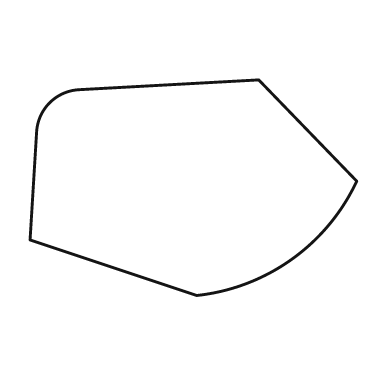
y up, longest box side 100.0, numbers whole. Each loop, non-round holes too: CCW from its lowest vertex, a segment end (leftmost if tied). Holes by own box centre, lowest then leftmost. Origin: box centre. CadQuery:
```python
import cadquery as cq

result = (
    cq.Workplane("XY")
    .moveTo(1.0, -33.0)
    .threePointArc((30.0, -22.0), (50.0, 2.0))
    .lineTo(20.0, 33.0)
    .lineTo(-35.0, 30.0)
    .threePointArc((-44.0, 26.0), (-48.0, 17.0))
    .lineTo(-50.0, -16.0)
    .close()
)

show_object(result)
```